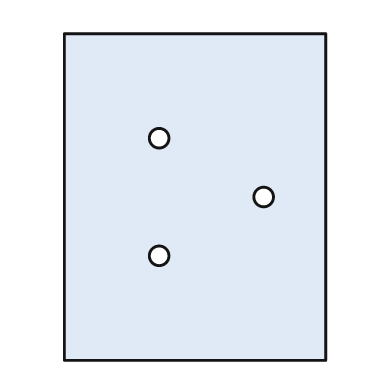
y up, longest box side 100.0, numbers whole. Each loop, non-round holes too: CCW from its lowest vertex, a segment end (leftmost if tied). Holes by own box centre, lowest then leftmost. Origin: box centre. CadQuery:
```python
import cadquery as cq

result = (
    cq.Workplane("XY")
    .moveTo(-40.0, -50.0)
    .lineTo(40.0, -50.0)
    .lineTo(40.0, 50.0)
    .lineTo(-40.0, 50.0)
    .close()
    .moveTo(-11.0, -18.0)
    .circle(3.0)
    .moveTo(21.0, 0.0)
    .circle(3.0)
    .moveTo(-11.0, 18.0)
    .circle(3.0)
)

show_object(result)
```